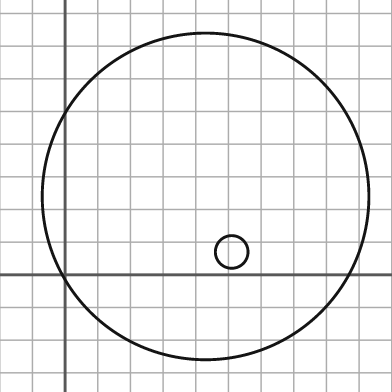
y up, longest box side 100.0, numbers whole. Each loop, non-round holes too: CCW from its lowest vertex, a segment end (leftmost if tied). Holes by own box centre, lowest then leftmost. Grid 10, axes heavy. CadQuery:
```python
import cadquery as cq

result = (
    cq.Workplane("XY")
    .moveTo(43.0, 24.0)
    .circle(50.0)
    .moveTo(51.0, 7.0)
    .circle(5.0)
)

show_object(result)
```